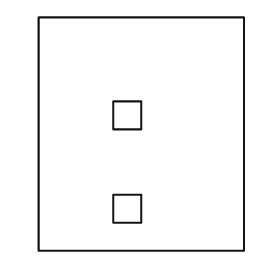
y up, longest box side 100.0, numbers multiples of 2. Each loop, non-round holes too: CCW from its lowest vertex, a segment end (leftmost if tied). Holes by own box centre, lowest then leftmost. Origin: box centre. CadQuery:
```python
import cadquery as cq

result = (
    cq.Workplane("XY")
    .moveTo(-44.0, -50.0)
    .lineTo(44.0, -50.0)
    .lineTo(44.0, 50.0)
    .lineTo(-44.0, 50.0)
    .close()
    .moveTo(-12.0, -38.0)
    .lineTo(0.0, -38.0)
    .lineTo(0.0, -26.0)
    .lineTo(-12.0, -26.0)
    .close()
    .moveTo(-12.0, 2.0)
    .lineTo(0.0, 2.0)
    .lineTo(0.0, 14.0)
    .lineTo(-12.0, 14.0)
    .close()
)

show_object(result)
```